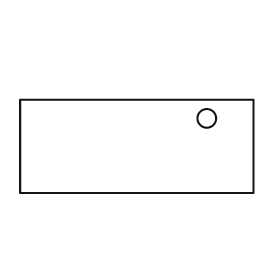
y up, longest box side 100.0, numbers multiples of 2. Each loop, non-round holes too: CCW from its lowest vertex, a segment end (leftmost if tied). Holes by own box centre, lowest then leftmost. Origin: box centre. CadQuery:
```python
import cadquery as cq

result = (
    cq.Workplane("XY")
    .moveTo(-50.0, -20.0)
    .lineTo(50.0, -20.0)
    .lineTo(50.0, 20.0)
    .lineTo(-50.0, 20.0)
    .close()
    .moveTo(30.0, 12.0)
    .circle(4.0)
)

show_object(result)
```